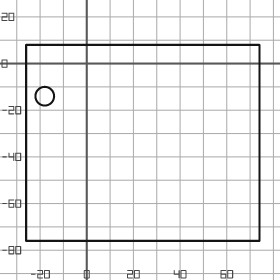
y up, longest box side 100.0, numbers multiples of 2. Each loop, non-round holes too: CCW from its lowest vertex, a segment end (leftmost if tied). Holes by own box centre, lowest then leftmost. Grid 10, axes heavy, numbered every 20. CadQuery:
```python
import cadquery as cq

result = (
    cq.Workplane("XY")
    .moveTo(-26.0, -76.0)
    .lineTo(74.0, -76.0)
    .lineTo(74.0, 8.0)
    .lineTo(-26.0, 8.0)
    .close()
    .moveTo(-18.0, -14.0)
    .circle(4.0)
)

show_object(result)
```